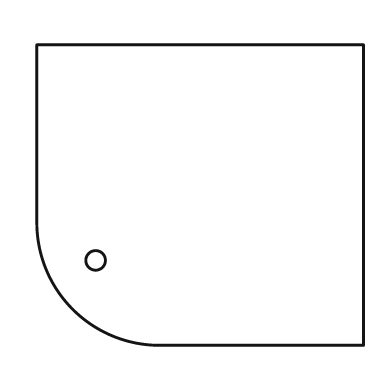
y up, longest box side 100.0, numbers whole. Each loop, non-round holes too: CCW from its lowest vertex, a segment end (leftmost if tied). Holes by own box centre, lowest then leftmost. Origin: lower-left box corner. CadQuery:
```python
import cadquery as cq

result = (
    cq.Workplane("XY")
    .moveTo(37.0, 0.0)
    .lineTo(100.0, 0.0)
    .lineTo(100.0, 92.0)
    .lineTo(0.0, 92.0)
    .lineTo(0.0, 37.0)
    .threePointArc((11.0, 11.0), (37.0, 0.0))
    .close()
    .moveTo(18.0, 26.0)
    .circle(3.0)
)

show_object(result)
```